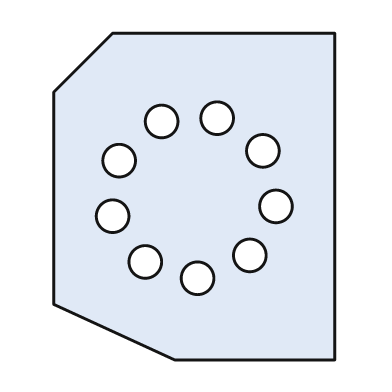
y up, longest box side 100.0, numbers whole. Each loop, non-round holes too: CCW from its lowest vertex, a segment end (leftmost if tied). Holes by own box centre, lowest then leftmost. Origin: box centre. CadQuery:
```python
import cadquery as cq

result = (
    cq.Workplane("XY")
    .moveTo(-6.0, -50.0)
    .lineTo(43.0, -50.0)
    .lineTo(43.0, 50.0)
    .lineTo(-25.0, 50.0)
    .lineTo(-43.0, 32.0)
    .lineTo(-43.0, -33.0)
    .close()
    .moveTo(1.0, -25.0)
    .circle(5.0)
    .moveTo(-15.0, -20.0)
    .circle(5.0)
    .moveTo(17.0, -18.0)
    .circle(5.0)
    .moveTo(-25.0, -6.0)
    .circle(5.0)
    .moveTo(25.0, -3.0)
    .circle(5.0)
    .moveTo(-23.0, 11.0)
    .circle(5.0)
    .moveTo(21.0, 14.0)
    .circle(5.0)
    .moveTo(-10.0, 23.0)
    .circle(5.0)
    .moveTo(7.0, 24.0)
    .circle(5.0)
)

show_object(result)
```